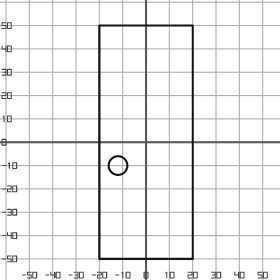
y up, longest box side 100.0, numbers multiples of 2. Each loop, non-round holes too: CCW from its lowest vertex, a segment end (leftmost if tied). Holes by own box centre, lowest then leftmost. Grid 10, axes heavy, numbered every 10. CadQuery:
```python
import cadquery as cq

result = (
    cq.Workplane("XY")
    .moveTo(-20.0, -50.0)
    .lineTo(20.0, -50.0)
    .lineTo(20.0, 50.0)
    .lineTo(-20.0, 50.0)
    .close()
    .moveTo(-12.0, -10.0)
    .circle(4.0)
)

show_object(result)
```